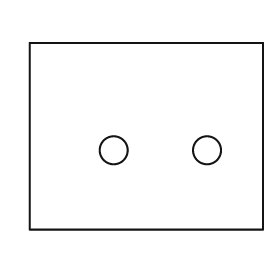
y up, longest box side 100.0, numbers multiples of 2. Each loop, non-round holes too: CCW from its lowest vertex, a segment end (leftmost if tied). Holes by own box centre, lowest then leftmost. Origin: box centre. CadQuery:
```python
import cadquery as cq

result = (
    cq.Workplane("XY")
    .moveTo(-50.0, -40.0)
    .lineTo(50.0, -40.0)
    .lineTo(50.0, 40.0)
    .lineTo(-50.0, 40.0)
    .close()
    .moveTo(-14.0, -6.0)
    .circle(6.0)
    .moveTo(26.0, -6.0)
    .circle(6.0)
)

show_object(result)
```